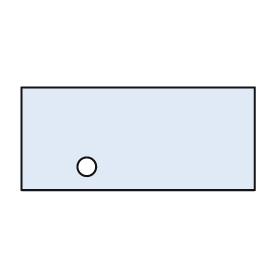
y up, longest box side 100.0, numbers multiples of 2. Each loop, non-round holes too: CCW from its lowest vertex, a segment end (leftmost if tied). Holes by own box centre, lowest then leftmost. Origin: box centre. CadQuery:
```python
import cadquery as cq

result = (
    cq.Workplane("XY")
    .moveTo(-50.0, -22.0)
    .lineTo(50.0, -22.0)
    .lineTo(50.0, 22.0)
    .lineTo(-50.0, 22.0)
    .close()
    .moveTo(-22.0, -12.0)
    .circle(4.0)
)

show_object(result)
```